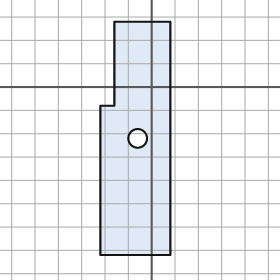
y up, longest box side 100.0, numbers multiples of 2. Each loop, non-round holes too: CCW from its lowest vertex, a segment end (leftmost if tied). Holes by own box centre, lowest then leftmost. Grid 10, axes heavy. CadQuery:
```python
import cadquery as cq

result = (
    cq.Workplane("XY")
    .moveTo(-22.0, -72.0)
    .lineTo(8.0, -72.0)
    .lineTo(8.0, 28.0)
    .lineTo(-16.0, 28.0)
    .lineTo(-16.0, -8.0)
    .lineTo(-22.0, -8.0)
    .close()
    .moveTo(-6.0, -22.0)
    .circle(4.0)
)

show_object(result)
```